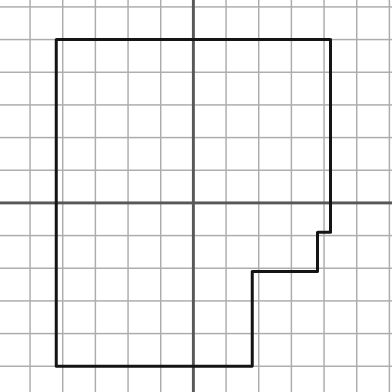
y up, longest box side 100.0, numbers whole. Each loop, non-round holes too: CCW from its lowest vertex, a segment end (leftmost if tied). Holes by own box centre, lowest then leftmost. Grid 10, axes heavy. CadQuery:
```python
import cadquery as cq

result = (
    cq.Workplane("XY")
    .moveTo(-42.0, -50.0)
    .lineTo(18.0, -50.0)
    .lineTo(18.0, -21.0)
    .lineTo(38.0, -21.0)
    .lineTo(38.0, -9.0)
    .lineTo(42.0, -9.0)
    .lineTo(42.0, 50.0)
    .lineTo(-42.0, 50.0)
    .close()
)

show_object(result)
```